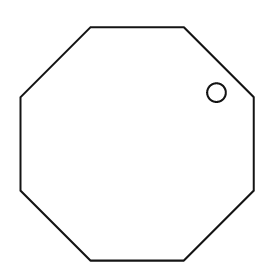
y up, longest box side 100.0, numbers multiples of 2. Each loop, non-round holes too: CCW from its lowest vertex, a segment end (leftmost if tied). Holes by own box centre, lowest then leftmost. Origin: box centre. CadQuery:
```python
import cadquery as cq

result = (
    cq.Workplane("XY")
    .moveTo(-20.0, -50.0)
    .lineTo(20.0, -50.0)
    .lineTo(50.0, -20.0)
    .lineTo(50.0, 20.0)
    .lineTo(20.0, 50.0)
    .lineTo(-20.0, 50.0)
    .lineTo(-50.0, 20.0)
    .lineTo(-50.0, -20.0)
    .close()
    .moveTo(34.0, 22.0)
    .circle(4.0)
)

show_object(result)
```